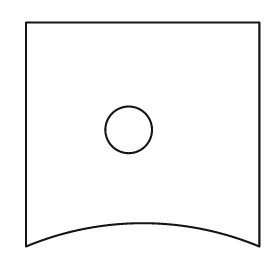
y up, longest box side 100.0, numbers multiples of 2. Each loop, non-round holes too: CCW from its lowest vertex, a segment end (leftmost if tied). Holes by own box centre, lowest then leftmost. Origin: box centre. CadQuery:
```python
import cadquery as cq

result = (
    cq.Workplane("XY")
    .moveTo(-50.0, -48.0)
    .threePointArc((0.0, -38.0), (50.0, -48.0))
    .lineTo(50.0, 48.0)
    .lineTo(-50.0, 48.0)
    .close()
    .moveTo(-6.0, 2.0)
    .circle(10.0)
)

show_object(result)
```